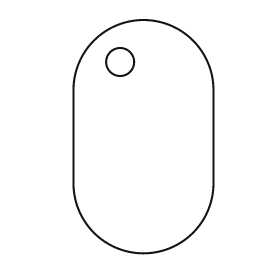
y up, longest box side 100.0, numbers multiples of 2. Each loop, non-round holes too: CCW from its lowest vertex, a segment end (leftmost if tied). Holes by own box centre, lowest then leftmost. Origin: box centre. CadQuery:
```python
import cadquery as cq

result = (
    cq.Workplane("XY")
    .moveTo(-30.0, -20.0)
    .threePointArc((0.0, -50.0), (30.0, -20.0))
    .lineTo(30.0, 20.0)
    .threePointArc((0.0, 50.0), (-30.0, 20.0))
    .close()
    .moveTo(-10.0, 32.0)
    .circle(6.0)
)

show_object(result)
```